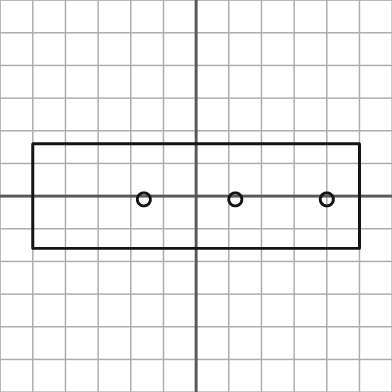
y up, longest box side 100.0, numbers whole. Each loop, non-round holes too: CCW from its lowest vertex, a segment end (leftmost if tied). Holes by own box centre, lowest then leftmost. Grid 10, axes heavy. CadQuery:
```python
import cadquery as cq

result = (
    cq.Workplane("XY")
    .moveTo(-50.0, -16.0)
    .lineTo(50.0, -16.0)
    .lineTo(50.0, 16.0)
    .lineTo(-50.0, 16.0)
    .close()
    .moveTo(-16.0, -1.0)
    .circle(2.0)
    .moveTo(12.0, -1.0)
    .circle(2.0)
    .moveTo(40.0, -1.0)
    .circle(2.0)
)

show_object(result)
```